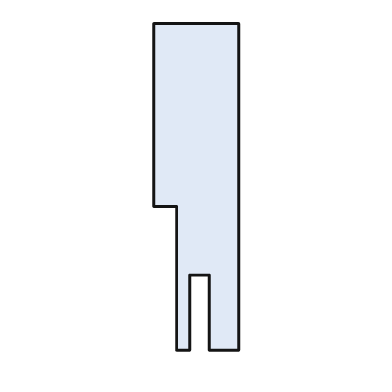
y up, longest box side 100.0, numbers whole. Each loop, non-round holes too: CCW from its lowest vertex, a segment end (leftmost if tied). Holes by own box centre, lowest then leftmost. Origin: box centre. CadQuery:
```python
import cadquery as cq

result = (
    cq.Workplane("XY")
    .moveTo(-6.0, -50.0)
    .lineTo(-2.0, -50.0)
    .lineTo(-2.0, -27.0)
    .lineTo(4.0, -27.0)
    .lineTo(4.0, -50.0)
    .lineTo(13.0, -50.0)
    .lineTo(13.0, 50.0)
    .lineTo(-13.0, 50.0)
    .lineTo(-13.0, -6.0)
    .lineTo(-6.0, -6.0)
    .close()
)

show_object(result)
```